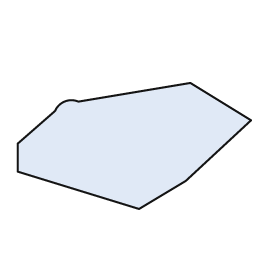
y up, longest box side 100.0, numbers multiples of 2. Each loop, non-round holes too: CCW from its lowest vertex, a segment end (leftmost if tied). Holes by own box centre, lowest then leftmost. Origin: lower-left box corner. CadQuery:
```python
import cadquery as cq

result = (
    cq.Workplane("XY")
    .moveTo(52.0, 0.0)
    .lineTo(72.0, 12.0)
    .lineTo(100.0, 38.0)
    .lineTo(74.0, 54.0)
    .lineTo(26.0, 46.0)
    .threePointArc((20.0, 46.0), (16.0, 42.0))
    .lineTo(0.0, 28.0)
    .lineTo(0.0, 16.0)
    .close()
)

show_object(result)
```